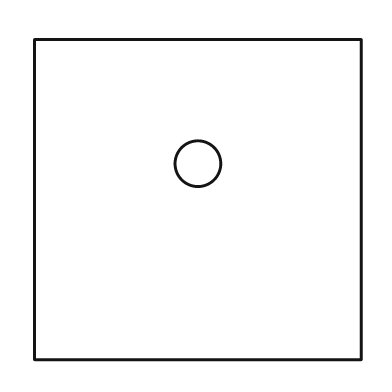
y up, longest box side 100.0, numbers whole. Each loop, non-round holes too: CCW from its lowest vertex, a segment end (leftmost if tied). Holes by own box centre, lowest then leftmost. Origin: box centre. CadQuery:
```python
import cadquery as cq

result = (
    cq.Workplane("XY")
    .moveTo(-50.0, -49.0)
    .lineTo(50.0, -49.0)
    .lineTo(50.0, 49.0)
    .lineTo(-50.0, 49.0)
    .close()
    .moveTo(0.0, 11.0)
    .circle(7.0)
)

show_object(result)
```